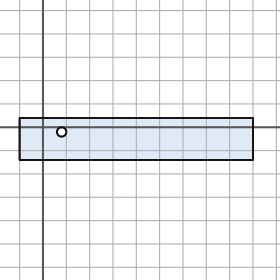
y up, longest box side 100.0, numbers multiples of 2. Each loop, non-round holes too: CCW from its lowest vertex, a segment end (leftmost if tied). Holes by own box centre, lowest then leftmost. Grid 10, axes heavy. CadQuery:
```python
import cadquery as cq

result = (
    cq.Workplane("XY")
    .moveTo(-10.0, -14.0)
    .lineTo(90.0, -14.0)
    .lineTo(90.0, 4.0)
    .lineTo(-10.0, 4.0)
    .close()
    .moveTo(8.0, -2.0)
    .circle(2.0)
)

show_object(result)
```